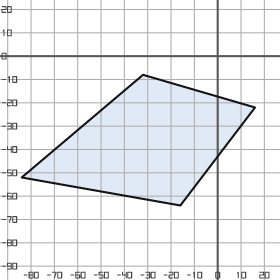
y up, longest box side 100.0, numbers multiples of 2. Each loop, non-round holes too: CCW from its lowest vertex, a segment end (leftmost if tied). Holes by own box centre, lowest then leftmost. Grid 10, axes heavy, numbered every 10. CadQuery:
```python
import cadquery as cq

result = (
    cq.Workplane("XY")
    .moveTo(-16.0, -64.0)
    .lineTo(16.0, -22.0)
    .lineTo(-32.0, -8.0)
    .lineTo(-84.0, -52.0)
    .close()
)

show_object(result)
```